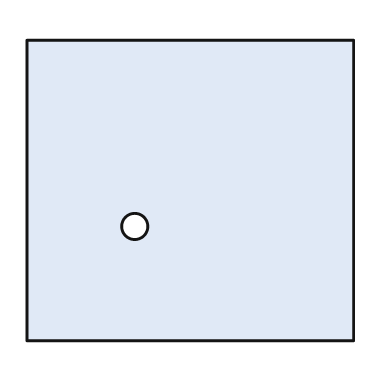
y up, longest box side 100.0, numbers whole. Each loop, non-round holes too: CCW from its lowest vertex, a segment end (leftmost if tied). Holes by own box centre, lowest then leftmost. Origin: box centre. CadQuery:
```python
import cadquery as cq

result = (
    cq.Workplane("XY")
    .moveTo(-50.0, -46.0)
    .lineTo(50.0, -46.0)
    .lineTo(50.0, 46.0)
    .lineTo(-50.0, 46.0)
    .close()
    .moveTo(-17.0, -11.0)
    .circle(4.0)
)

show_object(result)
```